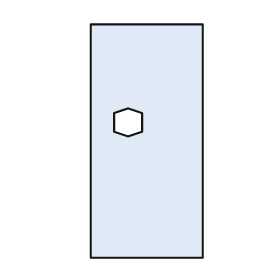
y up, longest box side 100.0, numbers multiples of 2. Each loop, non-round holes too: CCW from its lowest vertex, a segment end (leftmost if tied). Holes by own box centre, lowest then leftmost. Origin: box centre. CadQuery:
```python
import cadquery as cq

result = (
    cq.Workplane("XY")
    .moveTo(-24.0, -50.0)
    .lineTo(24.0, -50.0)
    .lineTo(24.0, 50.0)
    .lineTo(-24.0, 50.0)
    .close()
    .moveTo(-8.0, 2.0)
    .lineTo(-2.0, 4.0)
    .lineTo(-2.0, 12.0)
    .lineTo(-8.0, 14.0)
    .lineTo(-14.0, 12.0)
    .lineTo(-14.0, 4.0)
    .close()
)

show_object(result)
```